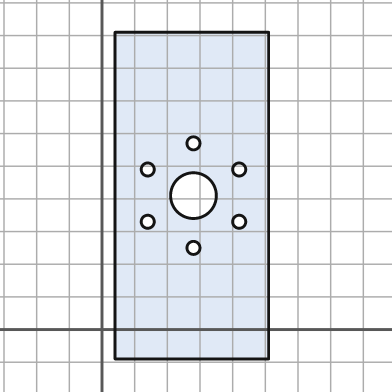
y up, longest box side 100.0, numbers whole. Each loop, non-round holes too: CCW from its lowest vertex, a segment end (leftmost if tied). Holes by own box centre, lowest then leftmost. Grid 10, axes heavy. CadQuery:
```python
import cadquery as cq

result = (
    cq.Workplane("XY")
    .moveTo(4.0, -9.0)
    .lineTo(51.0, -9.0)
    .lineTo(51.0, 91.0)
    .lineTo(4.0, 91.0)
    .close()
    .moveTo(28.0, 25.0)
    .circle(2.0)
    .moveTo(14.0, 33.0)
    .circle(2.0)
    .moveTo(42.0, 33.0)
    .circle(2.0)
    .moveTo(28.0, 41.0)
    .circle(7.0)
    .moveTo(14.0, 49.0)
    .circle(2.0)
    .moveTo(42.0, 49.0)
    .circle(2.0)
    .moveTo(28.0, 57.0)
    .circle(2.0)
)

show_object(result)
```